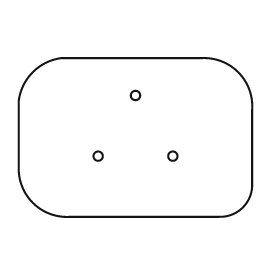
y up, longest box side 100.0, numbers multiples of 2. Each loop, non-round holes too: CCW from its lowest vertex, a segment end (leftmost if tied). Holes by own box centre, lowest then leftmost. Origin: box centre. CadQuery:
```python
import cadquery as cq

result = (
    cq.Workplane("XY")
    .moveTo(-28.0, -34.0)
    .lineTo(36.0, -34.0)
    .threePointArc((46.0, -30.0), (50.0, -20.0))
    .lineTo(50.0, 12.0)
    .threePointArc((44.0, 28.0), (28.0, 34.0))
    .lineTo(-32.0, 34.0)
    .threePointArc((-44.0, 28.0), (-50.0, 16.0))
    .lineTo(-50.0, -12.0)
    .threePointArc((-44.0, -28.0), (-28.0, -34.0))
    .close()
    .moveTo(-16.0, -8.0)
    .circle(2.0)
    .moveTo(16.0, -8.0)
    .circle(2.0)
    .moveTo(0.0, 18.0)
    .circle(2.0)
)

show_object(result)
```